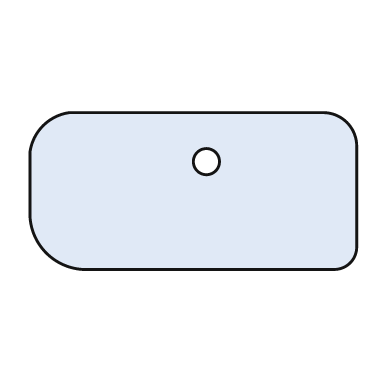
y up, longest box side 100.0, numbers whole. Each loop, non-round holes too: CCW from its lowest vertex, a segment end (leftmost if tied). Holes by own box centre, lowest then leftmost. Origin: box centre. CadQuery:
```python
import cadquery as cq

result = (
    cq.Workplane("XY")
    .moveTo(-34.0, -24.0)
    .lineTo(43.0, -24.0)
    .threePointArc((48.0, -22.0), (50.0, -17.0))
    .lineTo(50.0, 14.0)
    .threePointArc((47.0, 21.0), (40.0, 24.0))
    .lineTo(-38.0, 24.0)
    .threePointArc((-46.0, 20.0), (-50.0, 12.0))
    .lineTo(-50.0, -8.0)
    .threePointArc((-45.0, -19.0), (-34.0, -24.0))
    .close()
    .moveTo(4.0, 9.0)
    .circle(4.0)
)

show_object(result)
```